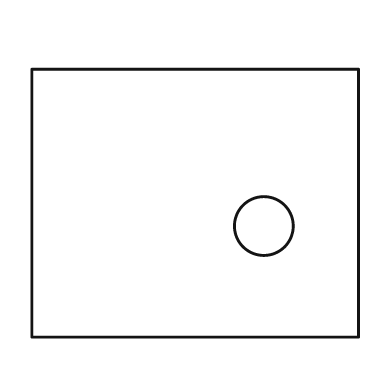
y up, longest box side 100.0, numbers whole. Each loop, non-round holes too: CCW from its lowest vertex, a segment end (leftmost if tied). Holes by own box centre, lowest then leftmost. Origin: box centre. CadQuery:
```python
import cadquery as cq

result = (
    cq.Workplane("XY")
    .moveTo(-50.0, -41.0)
    .lineTo(50.0, -41.0)
    .lineTo(50.0, 41.0)
    .lineTo(-50.0, 41.0)
    .close()
    .moveTo(21.0, -7.0)
    .circle(9.0)
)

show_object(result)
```